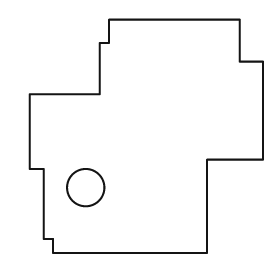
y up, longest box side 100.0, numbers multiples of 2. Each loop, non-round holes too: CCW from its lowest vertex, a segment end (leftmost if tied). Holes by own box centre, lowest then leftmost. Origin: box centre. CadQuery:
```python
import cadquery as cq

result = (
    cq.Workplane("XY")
    .moveTo(-40.0, -50.0)
    .lineTo(26.0, -50.0)
    .lineTo(26.0, -10.0)
    .lineTo(50.0, -10.0)
    .lineTo(50.0, 32.0)
    .lineTo(40.0, 32.0)
    .lineTo(40.0, 50.0)
    .lineTo(-16.0, 50.0)
    .lineTo(-16.0, 40.0)
    .lineTo(-20.0, 40.0)
    .lineTo(-20.0, 18.0)
    .lineTo(-50.0, 18.0)
    .lineTo(-50.0, -14.0)
    .lineTo(-44.0, -14.0)
    .lineTo(-44.0, -44.0)
    .lineTo(-40.0, -44.0)
    .close()
    .moveTo(-26.0, -22.0)
    .circle(8.0)
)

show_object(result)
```